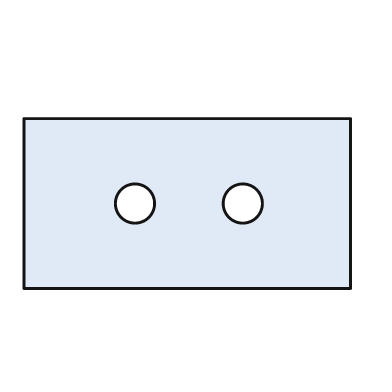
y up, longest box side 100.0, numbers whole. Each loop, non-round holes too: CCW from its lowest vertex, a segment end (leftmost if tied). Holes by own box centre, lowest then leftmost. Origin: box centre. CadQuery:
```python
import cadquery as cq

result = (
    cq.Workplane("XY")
    .moveTo(-50.0, -26.0)
    .lineTo(50.0, -26.0)
    .lineTo(50.0, 26.0)
    .lineTo(-50.0, 26.0)
    .close()
    .moveTo(-16.0, 0.0)
    .circle(6.0)
    .moveTo(17.0, 0.0)
    .circle(6.0)
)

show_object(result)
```